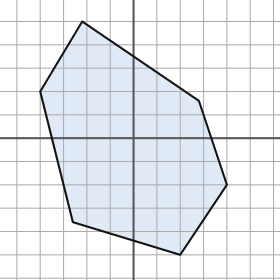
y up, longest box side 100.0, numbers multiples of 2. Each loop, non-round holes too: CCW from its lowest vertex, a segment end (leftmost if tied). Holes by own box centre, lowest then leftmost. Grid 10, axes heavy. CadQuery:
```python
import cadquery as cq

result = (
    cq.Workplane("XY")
    .moveTo(20.0, -50.0)
    .lineTo(40.0, -20.0)
    .lineTo(28.0, 16.0)
    .lineTo(-22.0, 50.0)
    .lineTo(-40.0, 20.0)
    .lineTo(-26.0, -36.0)
    .close()
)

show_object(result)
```